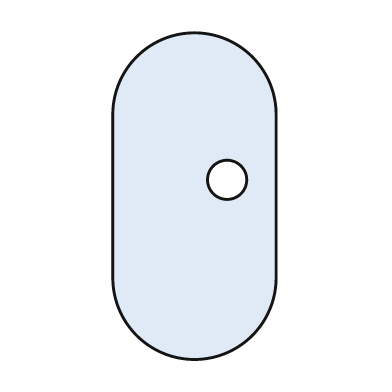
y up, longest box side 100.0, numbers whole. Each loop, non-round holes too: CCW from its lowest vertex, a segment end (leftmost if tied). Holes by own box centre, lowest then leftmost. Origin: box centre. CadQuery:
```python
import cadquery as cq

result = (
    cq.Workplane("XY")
    .moveTo(-25.0, -25.0)
    .threePointArc((0.0, -50.0), (25.0, -25.0))
    .lineTo(25.0, 25.0)
    .threePointArc((0.0, 50.0), (-25.0, 25.0))
    .close()
    .moveTo(10.0, 5.0)
    .circle(6.0)
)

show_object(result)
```